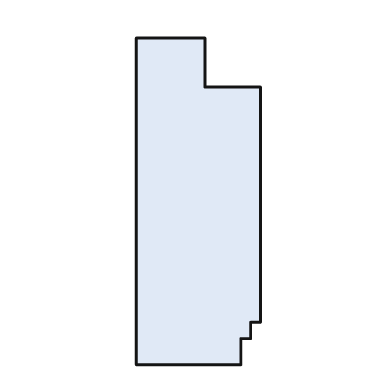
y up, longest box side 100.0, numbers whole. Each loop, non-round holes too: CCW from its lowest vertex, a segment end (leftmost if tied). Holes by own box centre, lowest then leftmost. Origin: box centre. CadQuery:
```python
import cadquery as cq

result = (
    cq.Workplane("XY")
    .moveTo(-19.0, -50.0)
    .lineTo(13.0, -50.0)
    .lineTo(13.0, -42.0)
    .lineTo(16.0, -42.0)
    .lineTo(16.0, -37.0)
    .lineTo(19.0, -37.0)
    .lineTo(19.0, 35.0)
    .lineTo(2.0, 35.0)
    .lineTo(2.0, 50.0)
    .lineTo(-19.0, 50.0)
    .close()
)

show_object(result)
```